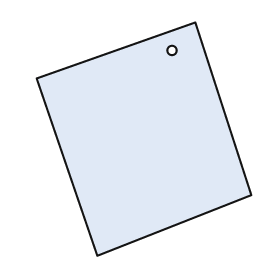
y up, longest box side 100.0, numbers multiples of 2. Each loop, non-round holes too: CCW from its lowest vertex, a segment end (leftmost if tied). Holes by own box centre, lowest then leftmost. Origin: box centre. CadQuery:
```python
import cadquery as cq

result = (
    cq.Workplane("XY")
    .moveTo(-20.0, -50.0)
    .lineTo(46.0, -24.0)
    .lineTo(22.0, 50.0)
    .lineTo(-46.0, 26.0)
    .close()
    .moveTo(12.0, 38.0)
    .circle(2.0)
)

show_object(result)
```